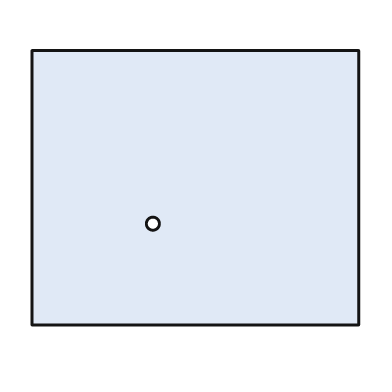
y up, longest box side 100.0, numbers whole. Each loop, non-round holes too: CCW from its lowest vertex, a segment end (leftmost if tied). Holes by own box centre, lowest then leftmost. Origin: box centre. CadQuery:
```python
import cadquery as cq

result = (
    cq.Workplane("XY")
    .moveTo(-50.0, -42.0)
    .lineTo(50.0, -42.0)
    .lineTo(50.0, 42.0)
    .lineTo(-50.0, 42.0)
    .close()
    .moveTo(-13.0, -11.0)
    .circle(2.0)
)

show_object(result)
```